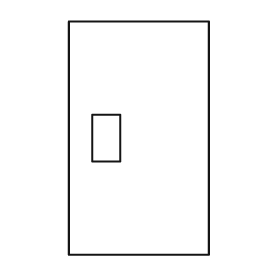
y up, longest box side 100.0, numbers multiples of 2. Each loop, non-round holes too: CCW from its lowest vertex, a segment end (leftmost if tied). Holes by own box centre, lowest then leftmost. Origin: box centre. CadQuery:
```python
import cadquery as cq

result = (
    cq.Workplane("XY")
    .moveTo(-30.0, -50.0)
    .lineTo(30.0, -50.0)
    .lineTo(30.0, 50.0)
    .lineTo(-30.0, 50.0)
    .close()
    .moveTo(-20.0, -10.0)
    .lineTo(-8.0, -10.0)
    .lineTo(-8.0, 10.0)
    .lineTo(-20.0, 10.0)
    .close()
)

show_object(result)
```